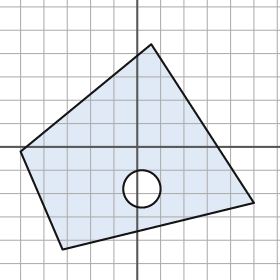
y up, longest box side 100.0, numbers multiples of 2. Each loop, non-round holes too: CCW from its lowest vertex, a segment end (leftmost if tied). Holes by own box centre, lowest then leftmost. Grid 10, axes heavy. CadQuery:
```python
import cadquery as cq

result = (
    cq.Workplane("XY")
    .moveTo(-32.0, -44.0)
    .lineTo(50.0, -24.0)
    .lineTo(6.0, 44.0)
    .lineTo(-50.0, -2.0)
    .close()
    .moveTo(2.0, -18.0)
    .circle(8.0)
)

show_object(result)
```